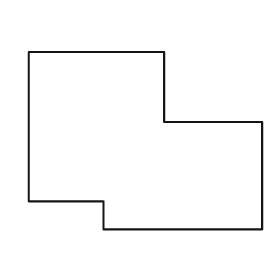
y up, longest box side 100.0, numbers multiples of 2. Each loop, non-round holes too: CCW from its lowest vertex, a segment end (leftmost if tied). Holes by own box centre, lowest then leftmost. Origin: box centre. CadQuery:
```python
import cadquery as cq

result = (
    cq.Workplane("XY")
    .moveTo(-18.0, -38.0)
    .lineTo(50.0, -38.0)
    .lineTo(50.0, 8.0)
    .lineTo(8.0, 8.0)
    .lineTo(8.0, 38.0)
    .lineTo(-50.0, 38.0)
    .lineTo(-50.0, -26.0)
    .lineTo(-18.0, -26.0)
    .close()
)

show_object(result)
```